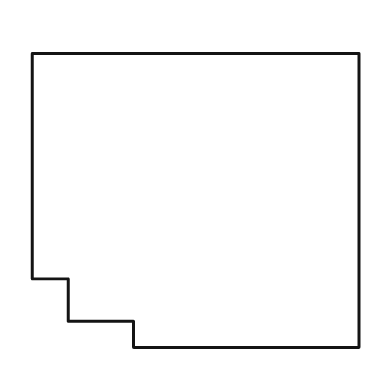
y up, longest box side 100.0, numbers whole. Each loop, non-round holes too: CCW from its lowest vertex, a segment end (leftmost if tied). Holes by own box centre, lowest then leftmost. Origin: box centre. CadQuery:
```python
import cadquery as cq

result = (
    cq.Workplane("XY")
    .moveTo(-19.0, -45.0)
    .lineTo(50.0, -45.0)
    .lineTo(50.0, 45.0)
    .lineTo(-50.0, 45.0)
    .lineTo(-50.0, -24.0)
    .lineTo(-39.0, -24.0)
    .lineTo(-39.0, -37.0)
    .lineTo(-19.0, -37.0)
    .close()
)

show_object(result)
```